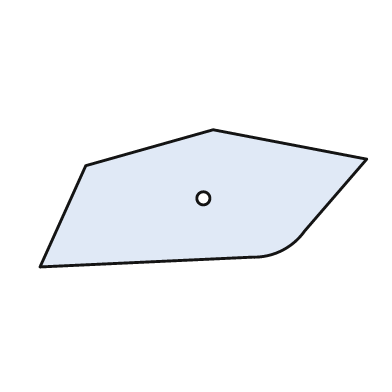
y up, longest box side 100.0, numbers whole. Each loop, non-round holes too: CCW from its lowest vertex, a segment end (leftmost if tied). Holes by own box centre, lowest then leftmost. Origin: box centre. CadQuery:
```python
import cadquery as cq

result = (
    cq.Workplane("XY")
    .moveTo(-50.0, -21.0)
    .lineTo(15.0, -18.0)
    .threePointArc((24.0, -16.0), (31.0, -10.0))
    .lineTo(50.0, 12.0)
    .lineTo(3.0, 21.0)
    .lineTo(-36.0, 10.0)
    .close()
    .moveTo(0.0, 0.0)
    .circle(2.0)
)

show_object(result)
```